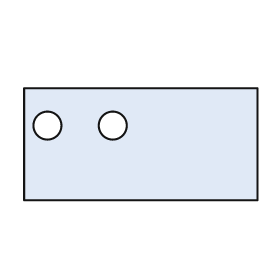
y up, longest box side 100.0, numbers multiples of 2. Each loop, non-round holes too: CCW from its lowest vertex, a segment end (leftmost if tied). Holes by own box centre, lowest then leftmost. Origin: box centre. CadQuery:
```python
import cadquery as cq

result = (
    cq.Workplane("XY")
    .moveTo(-50.0, -24.0)
    .lineTo(50.0, -24.0)
    .lineTo(50.0, 24.0)
    .lineTo(-50.0, 24.0)
    .close()
    .moveTo(-40.0, 8.0)
    .circle(6.0)
    .moveTo(-12.0, 8.0)
    .circle(6.0)
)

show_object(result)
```